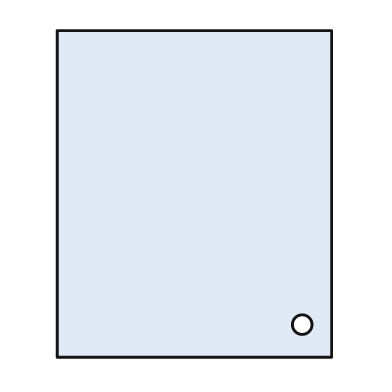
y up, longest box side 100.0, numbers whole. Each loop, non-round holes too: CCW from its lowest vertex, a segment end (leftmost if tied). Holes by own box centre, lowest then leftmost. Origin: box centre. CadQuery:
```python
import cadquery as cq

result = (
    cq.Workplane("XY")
    .moveTo(-42.0, -50.0)
    .lineTo(42.0, -50.0)
    .lineTo(42.0, 50.0)
    .lineTo(-42.0, 50.0)
    .close()
    .moveTo(33.0, -40.0)
    .circle(3.0)
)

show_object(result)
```